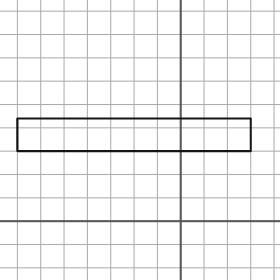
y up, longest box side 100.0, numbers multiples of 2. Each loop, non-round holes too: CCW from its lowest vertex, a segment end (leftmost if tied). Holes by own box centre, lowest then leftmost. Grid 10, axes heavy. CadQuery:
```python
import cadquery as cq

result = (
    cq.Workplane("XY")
    .moveTo(-70.0, 30.0)
    .lineTo(30.0, 30.0)
    .lineTo(30.0, 44.0)
    .lineTo(-70.0, 44.0)
    .close()
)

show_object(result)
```